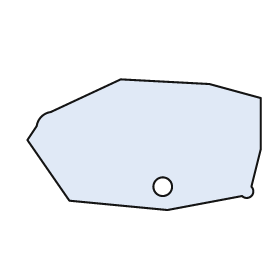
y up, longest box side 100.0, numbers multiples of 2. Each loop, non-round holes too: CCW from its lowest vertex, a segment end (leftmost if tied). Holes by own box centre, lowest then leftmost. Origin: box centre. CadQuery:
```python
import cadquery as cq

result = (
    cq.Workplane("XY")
    .moveTo(10.0, -28.0)
    .lineTo(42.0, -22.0)
    .threePointArc((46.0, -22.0), (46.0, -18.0))
    .lineTo(50.0, -2.0)
    .lineTo(50.0, 20.0)
    .lineTo(28.0, 26.0)
    .lineTo(-10.0, 28.0)
    .lineTo(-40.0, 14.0)
    .threePointArc((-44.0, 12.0), (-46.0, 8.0))
    .lineTo(-50.0, 2.0)
    .lineTo(-32.0, -24.0)
    .close()
    .moveTo(8.0, -18.0)
    .circle(4.0)
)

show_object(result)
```